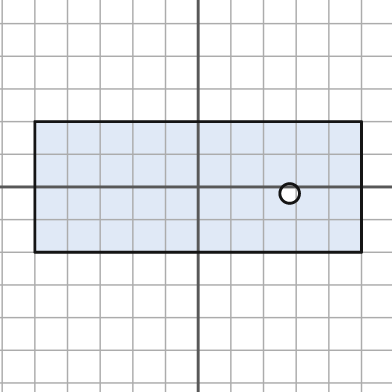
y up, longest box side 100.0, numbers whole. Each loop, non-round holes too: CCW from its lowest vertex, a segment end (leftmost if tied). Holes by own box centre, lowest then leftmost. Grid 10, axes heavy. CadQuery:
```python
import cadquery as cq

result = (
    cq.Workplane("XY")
    .moveTo(-50.0, -20.0)
    .lineTo(50.0, -20.0)
    .lineTo(50.0, 20.0)
    .lineTo(-50.0, 20.0)
    .close()
    .moveTo(28.0, -2.0)
    .circle(3.0)
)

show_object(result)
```